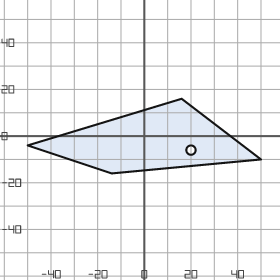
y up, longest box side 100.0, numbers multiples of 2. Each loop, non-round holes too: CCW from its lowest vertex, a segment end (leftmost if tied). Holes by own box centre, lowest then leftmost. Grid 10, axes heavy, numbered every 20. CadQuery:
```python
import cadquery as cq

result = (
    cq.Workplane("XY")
    .moveTo(-14.0, -16.0)
    .lineTo(50.0, -10.0)
    .lineTo(16.0, 16.0)
    .lineTo(-50.0, -4.0)
    .close()
    .moveTo(20.0, -6.0)
    .circle(2.0)
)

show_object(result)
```